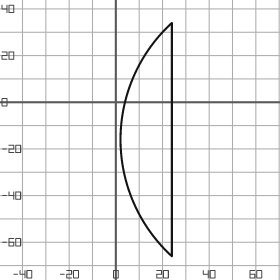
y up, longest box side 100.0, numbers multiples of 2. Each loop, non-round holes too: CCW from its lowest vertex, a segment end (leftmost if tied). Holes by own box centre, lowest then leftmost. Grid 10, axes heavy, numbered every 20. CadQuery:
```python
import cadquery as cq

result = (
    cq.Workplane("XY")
    .moveTo(24.0, -66.0)
    .lineTo(24.0, 34.0)
    .threePointArc((2.0, -16.0), (24.0, -66.0))
    .close()
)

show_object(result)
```